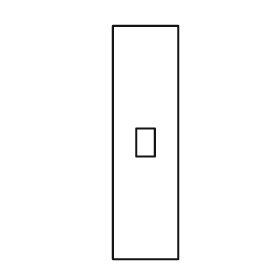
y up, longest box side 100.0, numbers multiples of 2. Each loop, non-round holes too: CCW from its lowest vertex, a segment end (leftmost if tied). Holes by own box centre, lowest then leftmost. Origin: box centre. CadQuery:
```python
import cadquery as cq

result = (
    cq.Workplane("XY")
    .moveTo(-14.0, -50.0)
    .lineTo(14.0, -50.0)
    .lineTo(14.0, 50.0)
    .lineTo(-14.0, 50.0)
    .close()
    .moveTo(-4.0, -6.0)
    .lineTo(4.0, -6.0)
    .lineTo(4.0, 6.0)
    .lineTo(-4.0, 6.0)
    .close()
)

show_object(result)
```